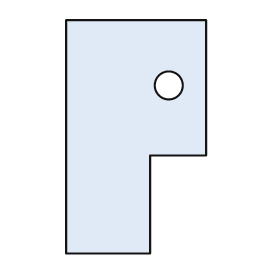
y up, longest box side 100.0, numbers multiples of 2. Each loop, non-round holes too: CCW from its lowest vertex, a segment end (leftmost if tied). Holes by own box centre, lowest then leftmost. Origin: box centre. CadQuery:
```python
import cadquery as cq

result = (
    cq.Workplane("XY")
    .moveTo(-30.0, -50.0)
    .lineTo(6.0, -50.0)
    .lineTo(6.0, -8.0)
    .lineTo(30.0, -8.0)
    .lineTo(30.0, 50.0)
    .lineTo(-30.0, 50.0)
    .close()
    .moveTo(14.0, 22.0)
    .circle(6.0)
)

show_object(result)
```